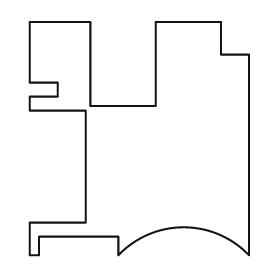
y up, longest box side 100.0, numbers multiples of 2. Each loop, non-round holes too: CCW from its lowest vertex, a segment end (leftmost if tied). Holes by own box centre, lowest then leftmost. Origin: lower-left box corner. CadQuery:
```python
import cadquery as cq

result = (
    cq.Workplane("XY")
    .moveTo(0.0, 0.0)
    .lineTo(4.0, 0.0)
    .lineTo(4.0, 8.0)
    .lineTo(38.0, 8.0)
    .lineTo(38.0, 0.0)
    .threePointArc((66.0, 12.0), (94.0, 0.0))
    .lineTo(94.0, 86.0)
    .lineTo(82.0, 86.0)
    .lineTo(82.0, 100.0)
    .lineTo(54.0, 100.0)
    .lineTo(54.0, 64.0)
    .lineTo(26.0, 64.0)
    .lineTo(26.0, 100.0)
    .lineTo(0.0, 100.0)
    .lineTo(0.0, 74.0)
    .lineTo(12.0, 74.0)
    .lineTo(12.0, 68.0)
    .lineTo(0.0, 68.0)
    .lineTo(0.0, 62.0)
    .lineTo(24.0, 62.0)
    .lineTo(24.0, 14.0)
    .lineTo(0.0, 14.0)
    .close()
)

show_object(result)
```